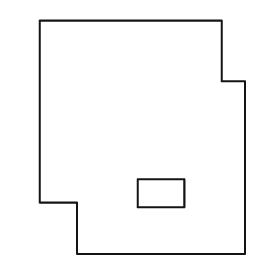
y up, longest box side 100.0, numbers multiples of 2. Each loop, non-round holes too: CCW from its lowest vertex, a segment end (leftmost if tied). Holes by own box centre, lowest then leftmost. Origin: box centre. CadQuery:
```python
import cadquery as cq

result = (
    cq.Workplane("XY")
    .moveTo(-28.0, -50.0)
    .lineTo(44.0, -50.0)
    .lineTo(44.0, 24.0)
    .lineTo(34.0, 24.0)
    .lineTo(34.0, 50.0)
    .lineTo(-44.0, 50.0)
    .lineTo(-44.0, -28.0)
    .lineTo(-28.0, -28.0)
    .close()
    .moveTo(-2.0, -30.0)
    .lineTo(18.0, -30.0)
    .lineTo(18.0, -18.0)
    .lineTo(-2.0, -18.0)
    .close()
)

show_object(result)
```